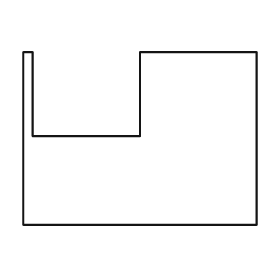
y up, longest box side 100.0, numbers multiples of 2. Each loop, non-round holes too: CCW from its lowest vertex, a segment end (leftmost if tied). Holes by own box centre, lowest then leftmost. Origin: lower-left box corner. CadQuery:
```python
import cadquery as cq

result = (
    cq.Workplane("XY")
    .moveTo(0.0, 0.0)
    .lineTo(100.0, 0.0)
    .lineTo(100.0, 74.0)
    .lineTo(50.0, 74.0)
    .lineTo(50.0, 38.0)
    .lineTo(4.0, 38.0)
    .lineTo(4.0, 74.0)
    .lineTo(0.0, 74.0)
    .close()
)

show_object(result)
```